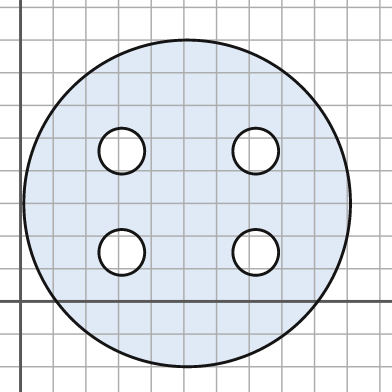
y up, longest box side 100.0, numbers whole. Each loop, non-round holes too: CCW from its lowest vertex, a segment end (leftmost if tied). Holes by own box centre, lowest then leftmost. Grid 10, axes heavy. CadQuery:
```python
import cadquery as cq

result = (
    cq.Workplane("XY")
    .moveTo(51.0, 30.0)
    .circle(50.0)
    .moveTo(31.0, 15.0)
    .circle(7.0)
    .moveTo(72.0, 15.0)
    .circle(7.0)
    .moveTo(31.0, 46.0)
    .circle(7.0)
    .moveTo(72.0, 46.0)
    .circle(7.0)
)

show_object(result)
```